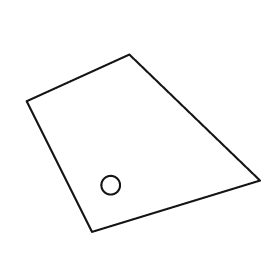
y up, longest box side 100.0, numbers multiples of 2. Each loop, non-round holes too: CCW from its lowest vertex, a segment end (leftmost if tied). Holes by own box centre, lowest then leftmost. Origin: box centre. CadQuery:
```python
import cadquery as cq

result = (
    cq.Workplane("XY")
    .moveTo(-22.0, -38.0)
    .lineTo(50.0, -16.0)
    .lineTo(-6.0, 38.0)
    .lineTo(-50.0, 18.0)
    .close()
    .moveTo(-14.0, -18.0)
    .circle(4.0)
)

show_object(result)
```